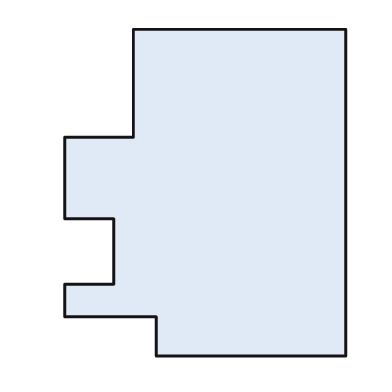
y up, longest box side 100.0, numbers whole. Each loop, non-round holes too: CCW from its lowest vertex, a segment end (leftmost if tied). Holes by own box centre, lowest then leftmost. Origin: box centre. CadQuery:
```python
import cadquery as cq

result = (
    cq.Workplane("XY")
    .moveTo(-15.0, -50.0)
    .lineTo(43.0, -50.0)
    .lineTo(43.0, 50.0)
    .lineTo(-22.0, 50.0)
    .lineTo(-22.0, 17.0)
    .lineTo(-43.0, 17.0)
    .lineTo(-43.0, -8.0)
    .lineTo(-28.0, -8.0)
    .lineTo(-28.0, -28.0)
    .lineTo(-43.0, -28.0)
    .lineTo(-43.0, -38.0)
    .lineTo(-15.0, -38.0)
    .close()
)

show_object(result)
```